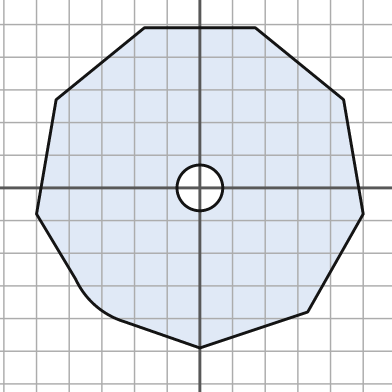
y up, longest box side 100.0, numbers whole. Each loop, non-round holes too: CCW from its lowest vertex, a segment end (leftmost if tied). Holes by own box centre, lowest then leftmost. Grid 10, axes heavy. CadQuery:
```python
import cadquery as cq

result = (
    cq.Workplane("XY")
    .moveTo(0.0, -49.0)
    .lineTo(33.0, -38.0)
    .lineTo(50.0, -8.0)
    .lineTo(44.0, 27.0)
    .lineTo(17.0, 49.0)
    .lineTo(-17.0, 49.0)
    .lineTo(-44.0, 27.0)
    .lineTo(-50.0, -8.0)
    .lineTo(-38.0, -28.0)
    .threePointArc((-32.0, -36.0), (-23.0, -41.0))
    .close()
    .moveTo(0.0, 0.0)
    .circle(7.0)
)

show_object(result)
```